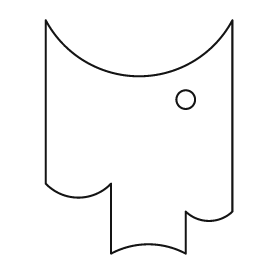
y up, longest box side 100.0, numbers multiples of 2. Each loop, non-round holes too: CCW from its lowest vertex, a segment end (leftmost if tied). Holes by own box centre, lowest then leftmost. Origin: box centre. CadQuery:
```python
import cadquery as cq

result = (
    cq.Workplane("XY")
    .moveTo(-12.0, -50.0)
    .threePointArc((4.0, -46.0), (20.0, -50.0))
    .lineTo(20.0, -32.0)
    .threePointArc((30.0, -36.0), (40.0, -32.0))
    .lineTo(40.0, 50.0)
    .threePointArc((0.0, 26.0), (-40.0, 50.0))
    .lineTo(-40.0, -20.0)
    .threePointArc((-26.0, -26.0), (-12.0, -20.0))
    .close()
    .moveTo(20.0, 16.0)
    .circle(4.0)
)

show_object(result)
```